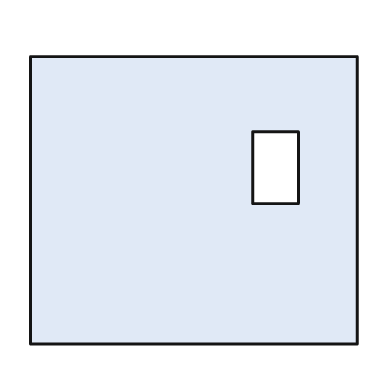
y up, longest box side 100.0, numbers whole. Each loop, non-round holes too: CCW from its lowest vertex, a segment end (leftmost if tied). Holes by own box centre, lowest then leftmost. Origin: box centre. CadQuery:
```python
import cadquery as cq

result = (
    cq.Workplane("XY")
    .moveTo(-50.0, -44.0)
    .lineTo(50.0, -44.0)
    .lineTo(50.0, 44.0)
    .lineTo(-50.0, 44.0)
    .close()
    .moveTo(18.0, -1.0)
    .lineTo(32.0, -1.0)
    .lineTo(32.0, 21.0)
    .lineTo(18.0, 21.0)
    .close()
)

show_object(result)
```